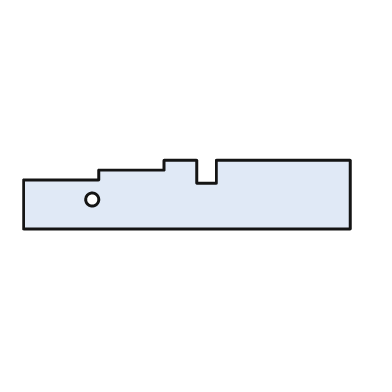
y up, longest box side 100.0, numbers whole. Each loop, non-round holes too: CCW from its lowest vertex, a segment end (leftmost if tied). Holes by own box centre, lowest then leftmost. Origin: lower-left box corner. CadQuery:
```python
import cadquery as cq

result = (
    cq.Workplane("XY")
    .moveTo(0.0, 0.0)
    .lineTo(100.0, 0.0)
    .lineTo(100.0, 21.0)
    .lineTo(59.0, 21.0)
    .lineTo(59.0, 14.0)
    .lineTo(53.0, 14.0)
    .lineTo(53.0, 21.0)
    .lineTo(43.0, 21.0)
    .lineTo(43.0, 18.0)
    .lineTo(23.0, 18.0)
    .lineTo(23.0, 15.0)
    .lineTo(0.0, 15.0)
    .close()
    .moveTo(21.0, 9.0)
    .circle(2.0)
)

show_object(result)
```